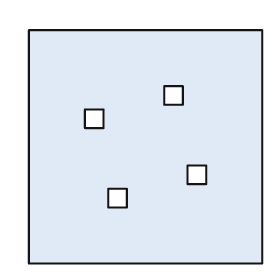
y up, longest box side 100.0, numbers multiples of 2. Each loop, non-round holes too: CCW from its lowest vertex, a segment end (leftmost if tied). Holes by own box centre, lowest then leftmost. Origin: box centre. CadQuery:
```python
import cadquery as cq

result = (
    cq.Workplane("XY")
    .moveTo(-50.0, -50.0)
    .lineTo(50.0, -50.0)
    .lineTo(50.0, 50.0)
    .lineTo(-50.0, 50.0)
    .close()
    .moveTo(-16.0, -26.0)
    .lineTo(-8.0, -26.0)
    .lineTo(-8.0, -18.0)
    .lineTo(-16.0, -18.0)
    .close()
    .moveTo(18.0, -16.0)
    .lineTo(26.0, -16.0)
    .lineTo(26.0, -8.0)
    .lineTo(18.0, -8.0)
    .close()
    .moveTo(-26.0, 8.0)
    .lineTo(-18.0, 8.0)
    .lineTo(-18.0, 16.0)
    .lineTo(-26.0, 16.0)
    .close()
    .moveTo(8.0, 18.0)
    .lineTo(16.0, 18.0)
    .lineTo(16.0, 26.0)
    .lineTo(8.0, 26.0)
    .close()
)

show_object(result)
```